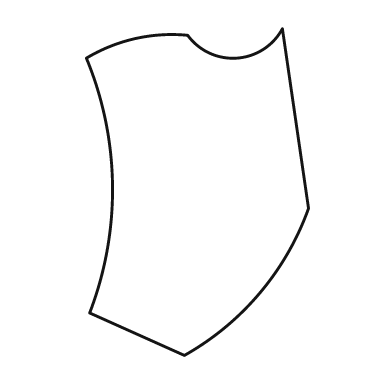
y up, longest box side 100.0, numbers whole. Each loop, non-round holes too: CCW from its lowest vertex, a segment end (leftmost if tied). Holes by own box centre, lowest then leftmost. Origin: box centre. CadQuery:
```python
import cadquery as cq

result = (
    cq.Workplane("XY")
    .moveTo(-4.0, -50.0)
    .threePointArc((19.0, -31.0), (34.0, -5.0))
    .lineTo(26.0, 50.0)
    .threePointArc((12.0, 41.0), (-3.0, 48.0))
    .threePointArc((-19.0, 47.0), (-34.0, 41.0))
    .threePointArc((-26.0, 2.0), (-33.0, -37.0))
    .close()
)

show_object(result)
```